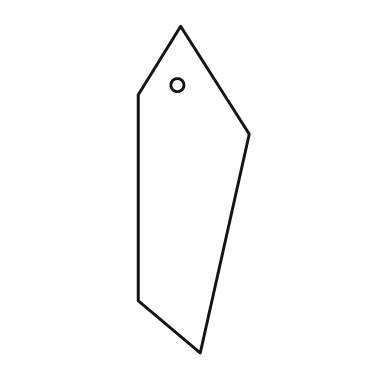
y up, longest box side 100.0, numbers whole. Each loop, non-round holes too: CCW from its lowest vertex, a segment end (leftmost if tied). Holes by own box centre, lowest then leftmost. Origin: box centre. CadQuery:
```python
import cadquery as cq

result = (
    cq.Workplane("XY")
    .moveTo(2.0, -50.0)
    .lineTo(17.0, 17.0)
    .lineTo(-4.0, 50.0)
    .lineTo(-17.0, 29.0)
    .lineTo(-17.0, -34.0)
    .close()
    .moveTo(-5.0, 32.0)
    .circle(2.0)
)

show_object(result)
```